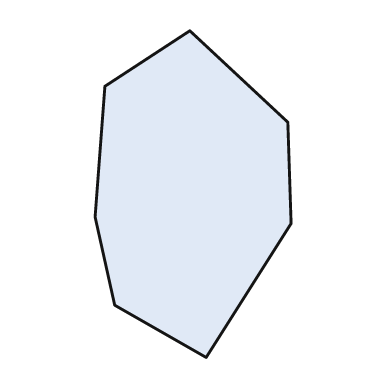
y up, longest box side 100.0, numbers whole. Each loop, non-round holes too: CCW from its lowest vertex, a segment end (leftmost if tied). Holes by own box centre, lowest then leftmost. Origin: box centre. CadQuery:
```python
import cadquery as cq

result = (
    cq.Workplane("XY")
    .moveTo(4.0, -50.0)
    .lineTo(30.0, -9.0)
    .lineTo(29.0, 22.0)
    .lineTo(-1.0, 50.0)
    .lineTo(-27.0, 33.0)
    .lineTo(-30.0, -7.0)
    .lineTo(-24.0, -34.0)
    .close()
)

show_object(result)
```